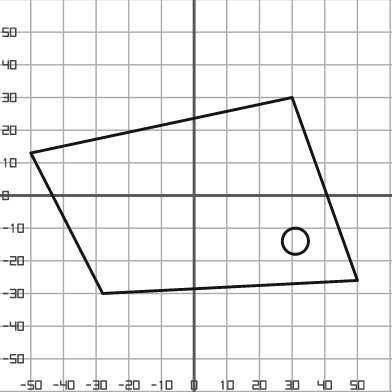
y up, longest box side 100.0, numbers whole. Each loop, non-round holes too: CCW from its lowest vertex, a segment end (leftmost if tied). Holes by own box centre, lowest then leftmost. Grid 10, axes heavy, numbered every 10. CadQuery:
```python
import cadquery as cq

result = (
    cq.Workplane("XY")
    .moveTo(-28.0, -30.0)
    .lineTo(50.0, -26.0)
    .lineTo(30.0, 30.0)
    .lineTo(-50.0, 13.0)
    .close()
    .moveTo(31.0, -14.0)
    .circle(4.0)
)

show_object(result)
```